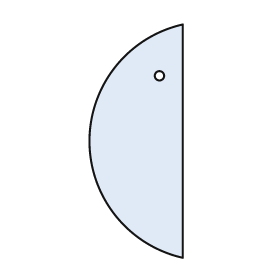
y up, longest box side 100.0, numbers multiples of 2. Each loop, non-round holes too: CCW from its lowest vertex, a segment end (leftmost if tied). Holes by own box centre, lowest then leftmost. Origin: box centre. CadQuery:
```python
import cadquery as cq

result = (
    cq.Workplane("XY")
    .moveTo(20.0, -50.0)
    .lineTo(20.0, 50.0)
    .threePointArc((-20.0, 0.0), (20.0, -50.0))
    .close()
    .moveTo(10.0, 28.0)
    .circle(2.0)
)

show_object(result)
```